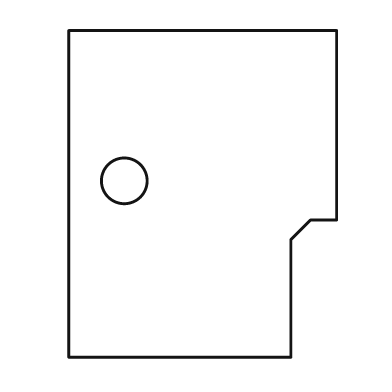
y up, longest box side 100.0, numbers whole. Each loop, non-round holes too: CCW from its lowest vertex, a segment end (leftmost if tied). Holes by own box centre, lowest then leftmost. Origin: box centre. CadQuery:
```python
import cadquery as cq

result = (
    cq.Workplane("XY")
    .moveTo(-41.0, -50.0)
    .lineTo(27.0, -50.0)
    .lineTo(27.0, -14.0)
    .lineTo(33.0, -8.0)
    .lineTo(41.0, -8.0)
    .lineTo(41.0, 50.0)
    .lineTo(-41.0, 50.0)
    .close()
    .moveTo(-24.0, 4.0)
    .circle(7.0)
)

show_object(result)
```